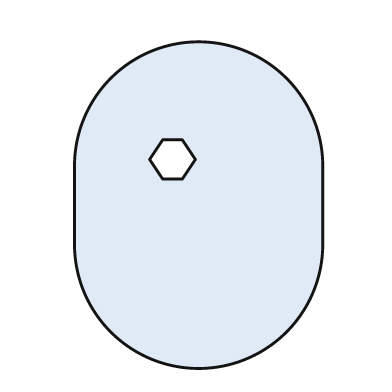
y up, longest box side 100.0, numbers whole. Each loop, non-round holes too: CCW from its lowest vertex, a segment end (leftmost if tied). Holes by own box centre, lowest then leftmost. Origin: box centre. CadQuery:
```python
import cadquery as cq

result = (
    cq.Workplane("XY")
    .moveTo(-38.0, -12.0)
    .threePointArc((0.0, -50.0), (38.0, -12.0))
    .lineTo(38.0, 12.0)
    .threePointArc((0.0, 50.0), (-38.0, 12.0))
    .close()
    .moveTo(-11.0, 8.0)
    .lineTo(-5.0, 8.0)
    .lineTo(-1.0, 14.0)
    .lineTo(-5.0, 20.0)
    .lineTo(-11.0, 20.0)
    .lineTo(-15.0, 14.0)
    .close()
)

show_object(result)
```